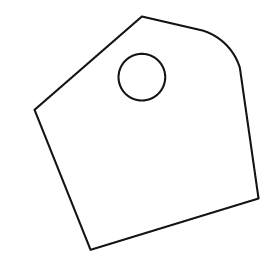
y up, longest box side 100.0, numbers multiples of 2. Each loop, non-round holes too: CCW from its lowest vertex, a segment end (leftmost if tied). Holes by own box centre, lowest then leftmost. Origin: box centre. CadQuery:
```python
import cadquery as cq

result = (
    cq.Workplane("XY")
    .moveTo(-24.0, -50.0)
    .lineTo(48.0, -28.0)
    .lineTo(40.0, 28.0)
    .threePointArc((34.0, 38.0), (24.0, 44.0))
    .lineTo(-2.0, 50.0)
    .lineTo(-48.0, 10.0)
    .close()
    .moveTo(-2.0, 24.0)
    .circle(10.0)
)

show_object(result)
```